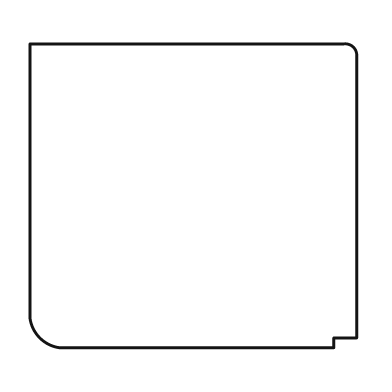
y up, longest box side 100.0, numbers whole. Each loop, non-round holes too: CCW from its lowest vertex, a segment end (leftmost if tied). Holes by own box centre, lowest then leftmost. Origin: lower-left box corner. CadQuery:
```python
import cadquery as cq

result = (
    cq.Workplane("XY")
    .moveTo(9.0, 0.0)
    .lineTo(93.0, 0.0)
    .lineTo(93.0, 3.0)
    .lineTo(100.0, 3.0)
    .lineTo(100.0, 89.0)
    .threePointArc((99.0, 92.0), (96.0, 93.0))
    .lineTo(0.0, 93.0)
    .lineTo(0.0, 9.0)
    .threePointArc((3.0, 3.0), (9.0, 0.0))
    .close()
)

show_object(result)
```